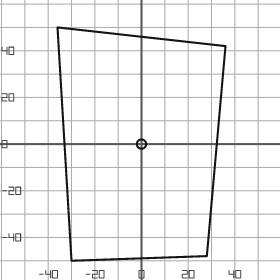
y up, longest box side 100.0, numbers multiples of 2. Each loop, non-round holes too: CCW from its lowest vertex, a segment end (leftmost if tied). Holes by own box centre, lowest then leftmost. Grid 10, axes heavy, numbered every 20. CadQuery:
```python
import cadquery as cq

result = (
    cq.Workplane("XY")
    .moveTo(-30.0, -50.0)
    .lineTo(28.0, -48.0)
    .lineTo(36.0, 42.0)
    .lineTo(-36.0, 50.0)
    .close()
    .moveTo(0.0, 0.0)
    .circle(2.0)
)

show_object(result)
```